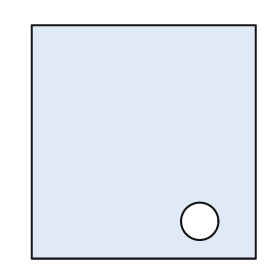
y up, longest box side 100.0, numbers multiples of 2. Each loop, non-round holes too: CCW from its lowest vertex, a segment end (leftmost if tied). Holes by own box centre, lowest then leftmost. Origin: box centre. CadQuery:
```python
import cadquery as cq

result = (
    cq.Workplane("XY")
    .moveTo(-48.0, -50.0)
    .lineTo(48.0, -50.0)
    .lineTo(48.0, 50.0)
    .lineTo(-48.0, 50.0)
    .close()
    .moveTo(24.0, -34.0)
    .circle(8.0)
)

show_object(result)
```